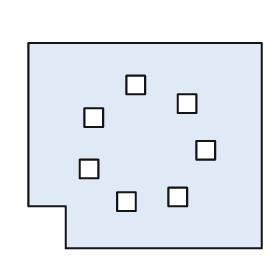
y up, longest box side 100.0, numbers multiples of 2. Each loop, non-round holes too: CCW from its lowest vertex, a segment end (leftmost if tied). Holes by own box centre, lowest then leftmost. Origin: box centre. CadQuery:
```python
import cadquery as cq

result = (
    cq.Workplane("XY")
    .moveTo(-34.0, -44.0)
    .lineTo(50.0, -44.0)
    .lineTo(50.0, 44.0)
    .lineTo(-50.0, 44.0)
    .lineTo(-50.0, -26.0)
    .lineTo(-34.0, -26.0)
    .close()
    .moveTo(-12.0, -28.0)
    .lineTo(-4.0, -28.0)
    .lineTo(-4.0, -20.0)
    .lineTo(-12.0, -20.0)
    .close()
    .moveTo(10.0, -26.0)
    .lineTo(18.0, -26.0)
    .lineTo(18.0, -18.0)
    .lineTo(10.0, -18.0)
    .close()
    .moveTo(-28.0, -14.0)
    .lineTo(-20.0, -14.0)
    .lineTo(-20.0, -6.0)
    .lineTo(-28.0, -6.0)
    .close()
    .moveTo(22.0, -6.0)
    .lineTo(30.0, -6.0)
    .lineTo(30.0, 2.0)
    .lineTo(22.0, 2.0)
    .close()
    .moveTo(-26.0, 8.0)
    .lineTo(-18.0, 8.0)
    .lineTo(-18.0, 16.0)
    .lineTo(-26.0, 16.0)
    .close()
    .moveTo(14.0, 14.0)
    .lineTo(22.0, 14.0)
    .lineTo(22.0, 22.0)
    .lineTo(14.0, 22.0)
    .close()
    .moveTo(-8.0, 22.0)
    .lineTo(0.0, 22.0)
    .lineTo(0.0, 30.0)
    .lineTo(-8.0, 30.0)
    .close()
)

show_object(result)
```